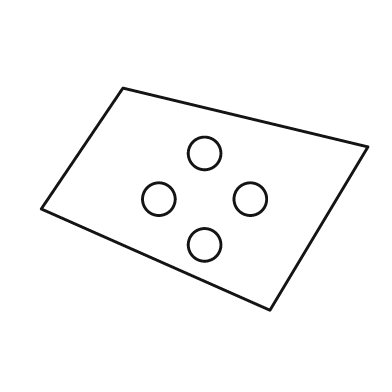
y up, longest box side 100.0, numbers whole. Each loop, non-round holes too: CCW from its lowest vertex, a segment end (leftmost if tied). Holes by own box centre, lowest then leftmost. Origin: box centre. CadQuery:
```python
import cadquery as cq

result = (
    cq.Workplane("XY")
    .moveTo(20.0, -34.0)
    .lineTo(50.0, 16.0)
    .lineTo(-25.0, 34.0)
    .lineTo(-50.0, -3.0)
    .close()
    .moveTo(0.0, -14.0)
    .circle(5.0)
    .moveTo(-14.0, 0.0)
    .circle(5.0)
    .moveTo(14.0, 0.0)
    .circle(5.0)
    .moveTo(0.0, 14.0)
    .circle(5.0)
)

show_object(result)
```